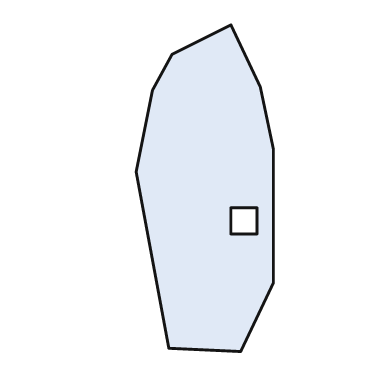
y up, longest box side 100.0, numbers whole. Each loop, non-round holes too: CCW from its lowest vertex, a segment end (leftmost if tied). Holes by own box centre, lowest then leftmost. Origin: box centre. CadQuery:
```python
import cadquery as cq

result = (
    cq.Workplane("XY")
    .moveTo(11.0, -50.0)
    .lineTo(21.0, -29.0)
    .lineTo(21.0, 12.0)
    .lineTo(17.0, 31.0)
    .lineTo(8.0, 50.0)
    .lineTo(-10.0, 41.0)
    .lineTo(-16.0, 30.0)
    .lineTo(-21.0, 5.0)
    .lineTo(-11.0, -49.0)
    .close()
    .moveTo(8.0, -14.0)
    .lineTo(16.0, -14.0)
    .lineTo(16.0, -6.0)
    .lineTo(8.0, -6.0)
    .close()
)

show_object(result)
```